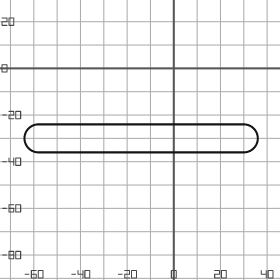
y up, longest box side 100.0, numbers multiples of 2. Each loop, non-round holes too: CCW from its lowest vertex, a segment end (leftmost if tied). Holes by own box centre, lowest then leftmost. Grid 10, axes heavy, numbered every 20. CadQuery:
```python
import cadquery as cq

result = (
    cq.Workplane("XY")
    .moveTo(-58.0, -36.0)
    .lineTo(30.0, -36.0)
    .threePointArc((36.0, -30.0), (30.0, -24.0))
    .lineTo(-58.0, -24.0)
    .threePointArc((-64.0, -30.0), (-58.0, -36.0))
    .close()
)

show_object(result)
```